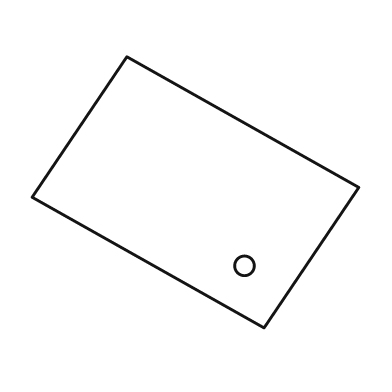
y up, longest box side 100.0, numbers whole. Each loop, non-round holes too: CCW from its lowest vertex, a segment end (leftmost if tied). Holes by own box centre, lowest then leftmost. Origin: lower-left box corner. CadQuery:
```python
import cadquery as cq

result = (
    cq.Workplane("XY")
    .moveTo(71.0, 0.0)
    .lineTo(100.0, 43.0)
    .lineTo(29.0, 83.0)
    .lineTo(0.0, 40.0)
    .close()
    .moveTo(65.0, 19.0)
    .circle(3.0)
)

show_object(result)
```